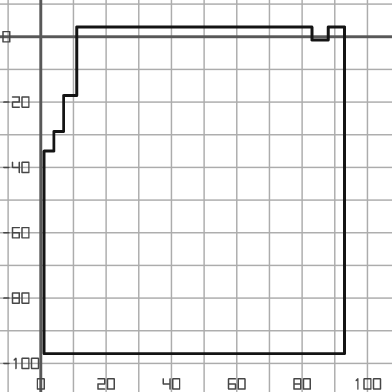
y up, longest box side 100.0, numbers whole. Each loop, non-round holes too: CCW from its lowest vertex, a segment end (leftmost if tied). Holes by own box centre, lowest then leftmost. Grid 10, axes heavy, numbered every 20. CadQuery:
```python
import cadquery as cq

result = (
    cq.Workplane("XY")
    .moveTo(1.0, -97.0)
    .lineTo(93.0, -97.0)
    .lineTo(93.0, 3.0)
    .lineTo(88.0, 3.0)
    .lineTo(88.0, -1.0)
    .lineTo(83.0, -1.0)
    .lineTo(83.0, 3.0)
    .lineTo(11.0, 3.0)
    .lineTo(11.0, -18.0)
    .lineTo(7.0, -18.0)
    .lineTo(7.0, -29.0)
    .lineTo(4.0, -29.0)
    .lineTo(4.0, -35.0)
    .lineTo(1.0, -35.0)
    .close()
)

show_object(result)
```